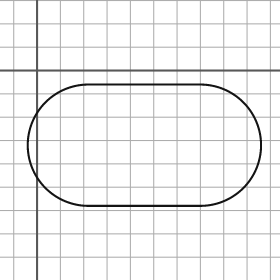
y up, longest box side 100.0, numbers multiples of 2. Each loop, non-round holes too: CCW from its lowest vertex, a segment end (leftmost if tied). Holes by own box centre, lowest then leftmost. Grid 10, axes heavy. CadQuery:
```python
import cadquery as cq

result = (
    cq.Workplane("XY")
    .moveTo(22.0, -58.0)
    .lineTo(70.0, -58.0)
    .threePointArc((96.0, -32.0), (70.0, -6.0))
    .lineTo(22.0, -6.0)
    .threePointArc((-4.0, -32.0), (22.0, -58.0))
    .close()
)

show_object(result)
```